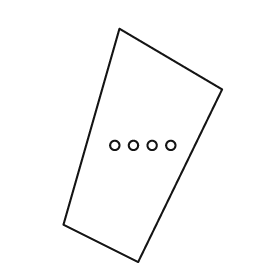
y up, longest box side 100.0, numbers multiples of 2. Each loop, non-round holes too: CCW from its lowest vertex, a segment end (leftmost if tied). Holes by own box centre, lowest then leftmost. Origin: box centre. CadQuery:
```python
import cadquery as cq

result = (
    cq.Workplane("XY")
    .moveTo(-2.0, -50.0)
    .lineTo(34.0, 24.0)
    .lineTo(-10.0, 50.0)
    .lineTo(-34.0, -34.0)
    .close()
    .moveTo(-12.0, 0.0)
    .circle(2.0)
    .moveTo(-4.0, 0.0)
    .circle(2.0)
    .moveTo(4.0, 0.0)
    .circle(2.0)
    .moveTo(12.0, 0.0)
    .circle(2.0)
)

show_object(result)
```